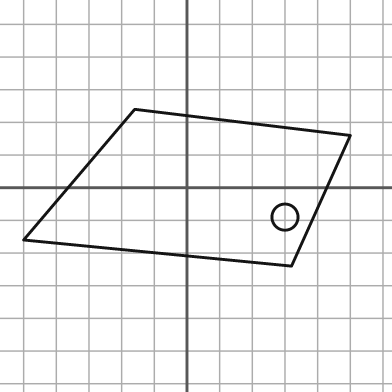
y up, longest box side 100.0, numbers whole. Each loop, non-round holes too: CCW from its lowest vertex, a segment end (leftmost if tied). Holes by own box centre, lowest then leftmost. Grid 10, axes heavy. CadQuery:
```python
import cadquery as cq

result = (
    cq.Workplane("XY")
    .moveTo(32.0, -24.0)
    .lineTo(50.0, 16.0)
    .lineTo(-16.0, 24.0)
    .lineTo(-50.0, -16.0)
    .close()
    .moveTo(30.0, -9.0)
    .circle(4.0)
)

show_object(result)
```